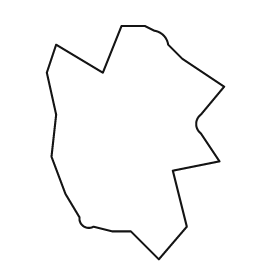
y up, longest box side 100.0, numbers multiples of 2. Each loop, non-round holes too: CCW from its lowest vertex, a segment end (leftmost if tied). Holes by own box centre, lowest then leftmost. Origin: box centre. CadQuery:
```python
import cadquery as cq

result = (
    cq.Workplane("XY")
    .moveTo(10.0, -50.0)
    .lineTo(22.0, -36.0)
    .lineTo(16.0, -12.0)
    .lineTo(36.0, -8.0)
    .lineTo(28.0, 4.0)
    .threePointArc((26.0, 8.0), (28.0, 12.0))
    .lineTo(38.0, 24.0)
    .lineTo(20.0, 36.0)
    .lineTo(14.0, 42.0)
    .threePointArc((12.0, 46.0), (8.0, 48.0))
    .lineTo(4.0, 50.0)
    .lineTo(-6.0, 50.0)
    .lineTo(-14.0, 30.0)
    .lineTo(-34.0, 42.0)
    .lineTo(-38.0, 30.0)
    .lineTo(-34.0, 12.0)
    .lineTo(-36.0, -6.0)
    .lineTo(-30.0, -22.0)
    .lineTo(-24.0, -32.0)
    .threePointArc((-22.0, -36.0), (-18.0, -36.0))
    .lineTo(-10.0, -38.0)
    .lineTo(-2.0, -38.0)
    .close()
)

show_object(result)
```